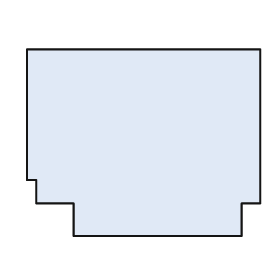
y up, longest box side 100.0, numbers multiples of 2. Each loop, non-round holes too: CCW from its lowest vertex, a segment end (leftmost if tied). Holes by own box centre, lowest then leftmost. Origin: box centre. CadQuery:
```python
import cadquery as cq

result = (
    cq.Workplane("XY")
    .moveTo(-30.0, -40.0)
    .lineTo(42.0, -40.0)
    .lineTo(42.0, -26.0)
    .lineTo(50.0, -26.0)
    .lineTo(50.0, 40.0)
    .lineTo(-50.0, 40.0)
    .lineTo(-50.0, -16.0)
    .lineTo(-46.0, -16.0)
    .lineTo(-46.0, -26.0)
    .lineTo(-30.0, -26.0)
    .close()
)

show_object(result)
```